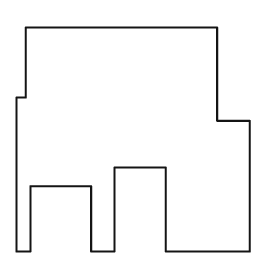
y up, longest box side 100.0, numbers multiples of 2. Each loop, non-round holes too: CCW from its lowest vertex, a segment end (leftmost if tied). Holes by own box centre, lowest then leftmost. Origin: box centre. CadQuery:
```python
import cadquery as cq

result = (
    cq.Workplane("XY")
    .moveTo(-50.0, -48.0)
    .lineTo(-44.0, -48.0)
    .lineTo(-44.0, -20.0)
    .lineTo(-18.0, -20.0)
    .lineTo(-18.0, -48.0)
    .lineTo(-8.0, -48.0)
    .lineTo(-8.0, -12.0)
    .lineTo(14.0, -12.0)
    .lineTo(14.0, -48.0)
    .lineTo(50.0, -48.0)
    .lineTo(50.0, 8.0)
    .lineTo(36.0, 8.0)
    .lineTo(36.0, 48.0)
    .lineTo(-46.0, 48.0)
    .lineTo(-46.0, 18.0)
    .lineTo(-50.0, 18.0)
    .close()
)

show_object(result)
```